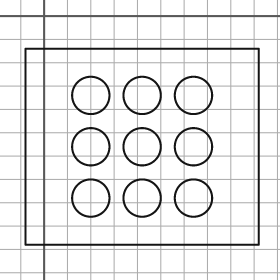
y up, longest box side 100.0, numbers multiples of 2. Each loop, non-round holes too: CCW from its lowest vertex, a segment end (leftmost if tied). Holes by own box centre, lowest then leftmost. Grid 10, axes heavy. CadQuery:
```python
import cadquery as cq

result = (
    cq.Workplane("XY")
    .moveTo(-8.0, -98.0)
    .lineTo(92.0, -98.0)
    .lineTo(92.0, -14.0)
    .lineTo(-8.0, -14.0)
    .close()
    .moveTo(20.0, -78.0)
    .circle(8.0)
    .moveTo(42.0, -78.0)
    .circle(8.0)
    .moveTo(64.0, -78.0)
    .circle(8.0)
    .moveTo(20.0, -56.0)
    .circle(8.0)
    .moveTo(42.0, -56.0)
    .circle(8.0)
    .moveTo(64.0, -56.0)
    .circle(8.0)
    .moveTo(20.0, -34.0)
    .circle(8.0)
    .moveTo(42.0, -34.0)
    .circle(8.0)
    .moveTo(64.0, -34.0)
    .circle(8.0)
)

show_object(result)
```